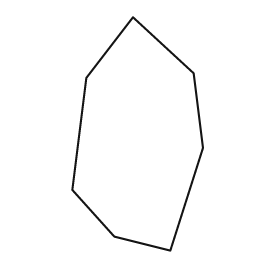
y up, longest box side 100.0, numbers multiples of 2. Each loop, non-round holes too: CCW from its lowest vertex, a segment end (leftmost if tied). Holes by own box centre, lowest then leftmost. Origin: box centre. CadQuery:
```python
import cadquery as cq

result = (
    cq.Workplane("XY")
    .moveTo(14.0, -50.0)
    .lineTo(28.0, -6.0)
    .lineTo(24.0, 26.0)
    .lineTo(-2.0, 50.0)
    .lineTo(-22.0, 24.0)
    .lineTo(-28.0, -24.0)
    .lineTo(-10.0, -44.0)
    .close()
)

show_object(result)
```